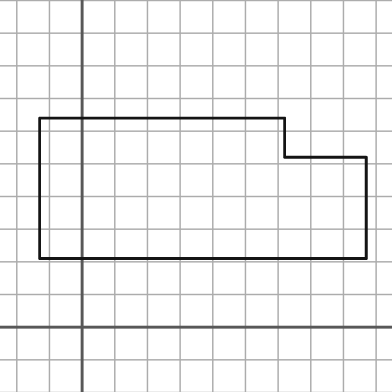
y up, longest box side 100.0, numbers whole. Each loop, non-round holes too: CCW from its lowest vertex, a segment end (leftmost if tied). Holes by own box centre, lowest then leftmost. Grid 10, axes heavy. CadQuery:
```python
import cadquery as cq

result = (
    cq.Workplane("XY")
    .moveTo(-13.0, 21.0)
    .lineTo(87.0, 21.0)
    .lineTo(87.0, 52.0)
    .lineTo(62.0, 52.0)
    .lineTo(62.0, 64.0)
    .lineTo(-13.0, 64.0)
    .close()
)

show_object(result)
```